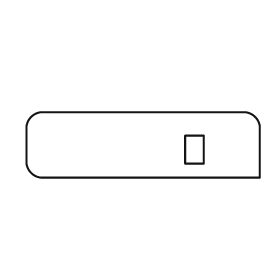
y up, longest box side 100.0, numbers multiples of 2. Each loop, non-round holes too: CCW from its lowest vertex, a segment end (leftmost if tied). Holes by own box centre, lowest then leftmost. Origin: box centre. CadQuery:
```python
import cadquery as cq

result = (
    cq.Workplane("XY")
    .moveTo(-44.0, -14.0)
    .lineTo(50.0, -14.0)
    .lineTo(50.0, 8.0)
    .threePointArc((48.0, 12.0), (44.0, 14.0))
    .lineTo(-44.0, 14.0)
    .threePointArc((-48.0, 12.0), (-50.0, 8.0))
    .lineTo(-50.0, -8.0)
    .threePointArc((-48.0, -12.0), (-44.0, -14.0))
    .close()
    .moveTo(18.0, -8.0)
    .lineTo(26.0, -8.0)
    .lineTo(26.0, 4.0)
    .lineTo(18.0, 4.0)
    .close()
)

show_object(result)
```